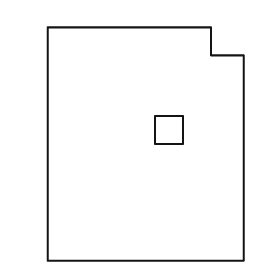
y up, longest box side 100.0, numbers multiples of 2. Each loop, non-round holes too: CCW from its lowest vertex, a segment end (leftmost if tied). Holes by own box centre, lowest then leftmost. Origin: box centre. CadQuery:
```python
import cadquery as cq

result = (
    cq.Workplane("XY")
    .moveTo(-42.0, -50.0)
    .lineTo(42.0, -50.0)
    .lineTo(42.0, 38.0)
    .lineTo(28.0, 38.0)
    .lineTo(28.0, 50.0)
    .lineTo(-42.0, 50.0)
    .close()
    .moveTo(4.0, 0.0)
    .lineTo(16.0, 0.0)
    .lineTo(16.0, 12.0)
    .lineTo(4.0, 12.0)
    .close()
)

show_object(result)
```